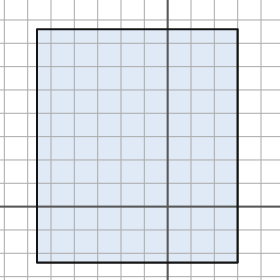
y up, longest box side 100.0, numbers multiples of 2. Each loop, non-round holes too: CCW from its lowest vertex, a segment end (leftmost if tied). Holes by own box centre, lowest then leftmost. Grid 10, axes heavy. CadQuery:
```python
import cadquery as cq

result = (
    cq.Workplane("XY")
    .moveTo(-56.0, -24.0)
    .lineTo(30.0, -24.0)
    .lineTo(30.0, 76.0)
    .lineTo(-56.0, 76.0)
    .close()
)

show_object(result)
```